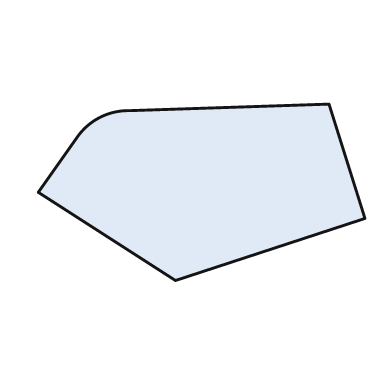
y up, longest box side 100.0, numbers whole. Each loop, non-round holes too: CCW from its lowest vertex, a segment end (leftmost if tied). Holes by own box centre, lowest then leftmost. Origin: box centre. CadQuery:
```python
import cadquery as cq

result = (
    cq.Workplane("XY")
    .moveTo(-8.0, -27.0)
    .lineTo(50.0, -8.0)
    .lineTo(39.0, 27.0)
    .lineTo(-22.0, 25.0)
    .threePointArc((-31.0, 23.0), (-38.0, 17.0))
    .lineTo(-50.0, 0.0)
    .close()
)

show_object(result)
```